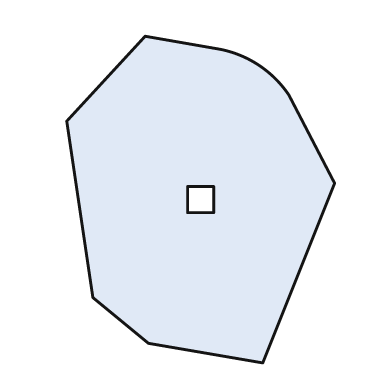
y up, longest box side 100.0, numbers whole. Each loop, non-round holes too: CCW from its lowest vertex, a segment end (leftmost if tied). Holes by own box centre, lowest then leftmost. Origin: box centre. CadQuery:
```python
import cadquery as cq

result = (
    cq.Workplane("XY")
    .moveTo(19.0, -50.0)
    .lineTo(41.0, 5.0)
    .lineTo(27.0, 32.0)
    .threePointArc((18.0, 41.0), (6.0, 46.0))
    .lineTo(-17.0, 50.0)
    .lineTo(-41.0, 24.0)
    .lineTo(-33.0, -30.0)
    .lineTo(-16.0, -44.0)
    .close()
    .moveTo(-4.0, -4.0)
    .lineTo(4.0, -4.0)
    .lineTo(4.0, 4.0)
    .lineTo(-4.0, 4.0)
    .close()
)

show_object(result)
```